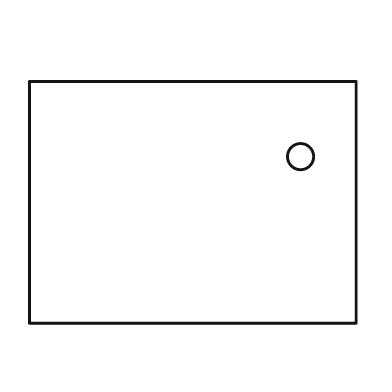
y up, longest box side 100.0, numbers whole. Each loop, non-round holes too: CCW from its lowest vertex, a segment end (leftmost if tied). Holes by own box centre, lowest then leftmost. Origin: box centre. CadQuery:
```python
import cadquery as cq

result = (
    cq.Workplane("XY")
    .moveTo(-50.0, -37.0)
    .lineTo(50.0, -37.0)
    .lineTo(50.0, 37.0)
    .lineTo(-50.0, 37.0)
    .close()
    .moveTo(33.0, 14.0)
    .circle(4.0)
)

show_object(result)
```